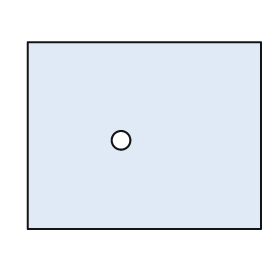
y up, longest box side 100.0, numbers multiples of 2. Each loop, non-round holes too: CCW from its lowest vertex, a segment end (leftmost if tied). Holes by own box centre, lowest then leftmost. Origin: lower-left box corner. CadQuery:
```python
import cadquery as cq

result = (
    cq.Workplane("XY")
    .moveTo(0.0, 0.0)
    .lineTo(100.0, 0.0)
    .lineTo(100.0, 80.0)
    .lineTo(0.0, 80.0)
    .close()
    .moveTo(40.0, 38.0)
    .circle(4.0)
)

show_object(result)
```